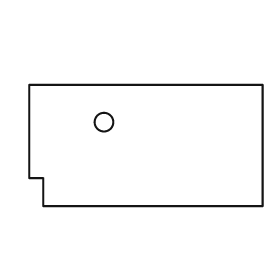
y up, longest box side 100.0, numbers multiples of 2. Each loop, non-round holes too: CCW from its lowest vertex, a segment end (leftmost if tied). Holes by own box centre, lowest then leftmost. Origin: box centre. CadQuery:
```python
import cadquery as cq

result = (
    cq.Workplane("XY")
    .moveTo(-44.0, -26.0)
    .lineTo(50.0, -26.0)
    .lineTo(50.0, 26.0)
    .lineTo(-50.0, 26.0)
    .lineTo(-50.0, -14.0)
    .lineTo(-44.0, -14.0)
    .close()
    .moveTo(-18.0, 10.0)
    .circle(4.0)
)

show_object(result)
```